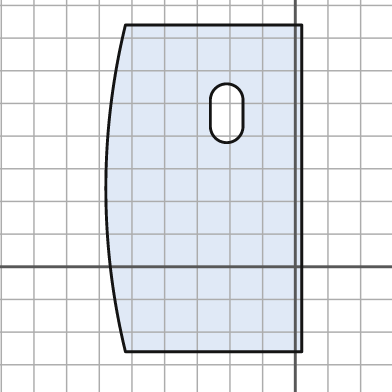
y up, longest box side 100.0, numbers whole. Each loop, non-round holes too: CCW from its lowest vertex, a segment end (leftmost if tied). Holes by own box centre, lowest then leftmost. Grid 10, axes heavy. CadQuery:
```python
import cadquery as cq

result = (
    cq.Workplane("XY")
    .moveTo(-52.0, -26.0)
    .lineTo(2.0, -26.0)
    .lineTo(2.0, 74.0)
    .lineTo(-52.0, 74.0)
    .threePointArc((-58.0, 24.0), (-52.0, -26.0))
    .close()
    .moveTo(-26.0, 43.0)
    .threePointArc((-21.0, 38.0), (-16.0, 43.0))
    .lineTo(-16.0, 51.0)
    .threePointArc((-21.0, 56.0), (-26.0, 51.0))
    .close()
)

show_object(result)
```